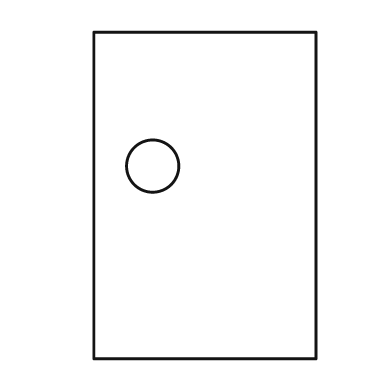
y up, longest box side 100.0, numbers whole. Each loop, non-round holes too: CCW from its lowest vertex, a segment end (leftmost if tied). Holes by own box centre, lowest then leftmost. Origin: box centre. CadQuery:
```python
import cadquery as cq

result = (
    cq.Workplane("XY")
    .moveTo(-34.0, -50.0)
    .lineTo(34.0, -50.0)
    .lineTo(34.0, 50.0)
    .lineTo(-34.0, 50.0)
    .close()
    .moveTo(-16.0, 9.0)
    .circle(8.0)
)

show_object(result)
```